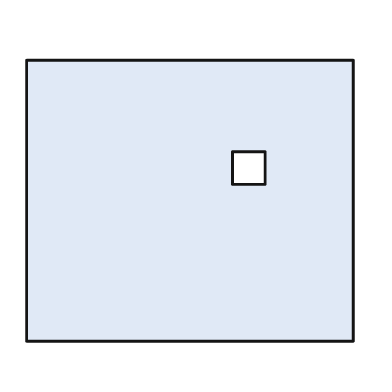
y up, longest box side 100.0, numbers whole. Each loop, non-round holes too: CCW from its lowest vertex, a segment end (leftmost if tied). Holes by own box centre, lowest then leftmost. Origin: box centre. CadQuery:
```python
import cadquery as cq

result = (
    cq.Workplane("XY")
    .moveTo(-50.0, -43.0)
    .lineTo(50.0, -43.0)
    .lineTo(50.0, 43.0)
    .lineTo(-50.0, 43.0)
    .close()
    .moveTo(13.0, 5.0)
    .lineTo(23.0, 5.0)
    .lineTo(23.0, 15.0)
    .lineTo(13.0, 15.0)
    .close()
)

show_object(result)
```